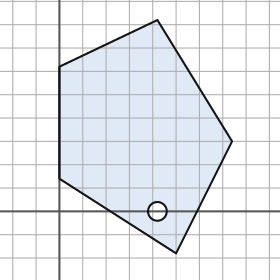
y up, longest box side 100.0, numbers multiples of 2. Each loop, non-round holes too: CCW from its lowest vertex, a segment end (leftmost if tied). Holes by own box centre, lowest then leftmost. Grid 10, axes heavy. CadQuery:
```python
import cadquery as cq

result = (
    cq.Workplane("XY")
    .moveTo(50.0, -18.0)
    .lineTo(74.0, 30.0)
    .lineTo(42.0, 82.0)
    .lineTo(0.0, 62.0)
    .lineTo(0.0, 14.0)
    .close()
    .moveTo(42.0, 0.0)
    .circle(4.0)
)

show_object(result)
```